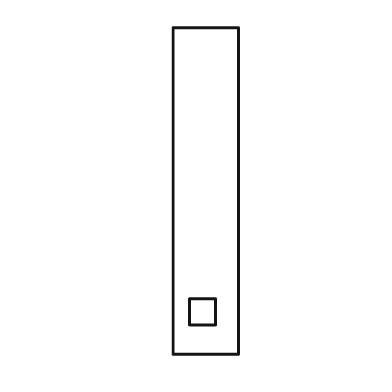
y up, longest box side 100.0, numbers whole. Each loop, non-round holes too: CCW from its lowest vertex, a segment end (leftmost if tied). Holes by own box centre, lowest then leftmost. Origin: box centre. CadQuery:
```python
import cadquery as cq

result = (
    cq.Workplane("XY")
    .moveTo(-10.0, -50.0)
    .lineTo(10.0, -50.0)
    .lineTo(10.0, 50.0)
    .lineTo(-10.0, 50.0)
    .close()
    .moveTo(-5.0, -41.0)
    .lineTo(3.0, -41.0)
    .lineTo(3.0, -33.0)
    .lineTo(-5.0, -33.0)
    .close()
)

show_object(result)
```